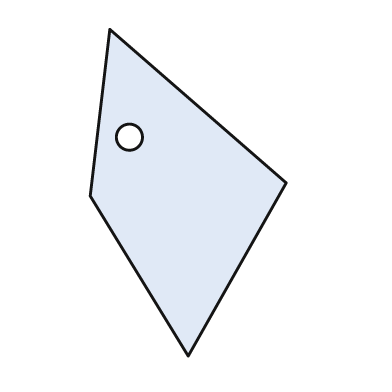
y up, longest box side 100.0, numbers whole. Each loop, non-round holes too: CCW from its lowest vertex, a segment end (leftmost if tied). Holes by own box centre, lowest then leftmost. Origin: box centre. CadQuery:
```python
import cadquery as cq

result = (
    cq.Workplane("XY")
    .moveTo(0.0, -50.0)
    .lineTo(30.0, 3.0)
    .lineTo(-24.0, 50.0)
    .lineTo(-30.0, -1.0)
    .close()
    .moveTo(-18.0, 17.0)
    .circle(4.0)
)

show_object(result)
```